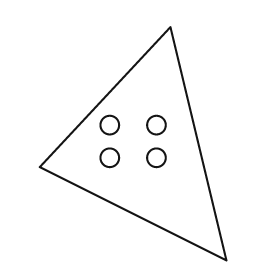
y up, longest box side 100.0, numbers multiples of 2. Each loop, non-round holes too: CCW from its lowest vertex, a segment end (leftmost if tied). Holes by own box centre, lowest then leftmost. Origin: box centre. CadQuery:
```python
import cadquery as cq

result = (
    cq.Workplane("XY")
    .moveTo(40.0, -50.0)
    .lineTo(16.0, 50.0)
    .lineTo(-40.0, -10.0)
    .close()
    .moveTo(-10.0, -6.0)
    .circle(4.0)
    .moveTo(10.0, -6.0)
    .circle(4.0)
    .moveTo(-10.0, 8.0)
    .circle(4.0)
    .moveTo(10.0, 8.0)
    .circle(4.0)
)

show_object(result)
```